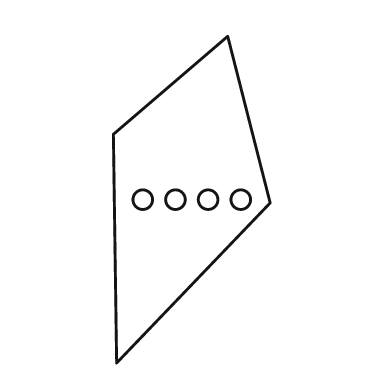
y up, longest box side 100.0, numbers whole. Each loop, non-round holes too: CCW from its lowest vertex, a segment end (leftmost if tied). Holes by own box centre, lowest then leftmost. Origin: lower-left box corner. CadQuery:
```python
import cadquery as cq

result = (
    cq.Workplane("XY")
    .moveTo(1.0, 0.0)
    .lineTo(48.0, 49.0)
    .lineTo(35.0, 100.0)
    .lineTo(0.0, 70.0)
    .close()
    .moveTo(9.0, 50.0)
    .circle(3.0)
    .moveTo(19.0, 50.0)
    .circle(3.0)
    .moveTo(29.0, 50.0)
    .circle(3.0)
    .moveTo(39.0, 50.0)
    .circle(3.0)
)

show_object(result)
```